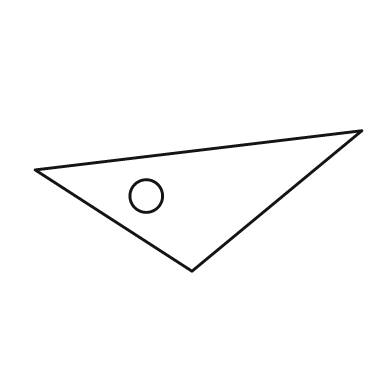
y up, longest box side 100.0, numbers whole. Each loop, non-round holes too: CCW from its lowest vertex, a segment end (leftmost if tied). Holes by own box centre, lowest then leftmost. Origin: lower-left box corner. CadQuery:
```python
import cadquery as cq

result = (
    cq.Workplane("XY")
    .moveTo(48.0, 0.0)
    .lineTo(100.0, 43.0)
    .lineTo(0.0, 31.0)
    .close()
    .moveTo(34.0, 23.0)
    .circle(5.0)
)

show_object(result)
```